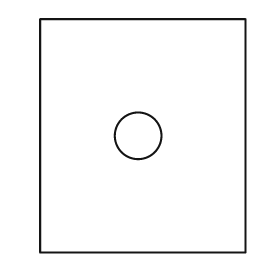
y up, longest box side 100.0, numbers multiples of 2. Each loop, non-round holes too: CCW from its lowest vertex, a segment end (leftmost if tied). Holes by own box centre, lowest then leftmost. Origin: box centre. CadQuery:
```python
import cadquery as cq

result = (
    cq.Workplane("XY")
    .moveTo(-44.0, -50.0)
    .lineTo(44.0, -50.0)
    .lineTo(44.0, 50.0)
    .lineTo(-44.0, 50.0)
    .close()
    .moveTo(-2.0, 0.0)
    .circle(10.0)
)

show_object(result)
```